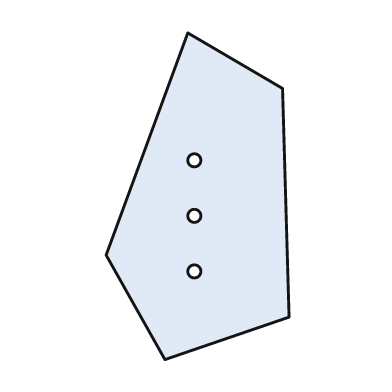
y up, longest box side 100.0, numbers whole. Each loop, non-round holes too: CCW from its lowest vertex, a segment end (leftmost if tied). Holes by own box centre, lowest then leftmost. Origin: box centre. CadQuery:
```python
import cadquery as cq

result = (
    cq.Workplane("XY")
    .moveTo(-10.0, -50.0)
    .lineTo(28.0, -37.0)
    .lineTo(26.0, 33.0)
    .lineTo(-3.0, 50.0)
    .lineTo(-28.0, -18.0)
    .close()
    .moveTo(-1.0, -23.0)
    .circle(2.0)
    .moveTo(-1.0, -6.0)
    .circle(2.0)
    .moveTo(-1.0, 11.0)
    .circle(2.0)
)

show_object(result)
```